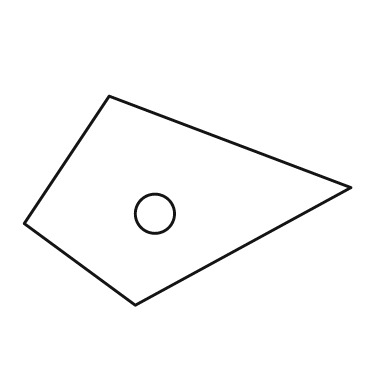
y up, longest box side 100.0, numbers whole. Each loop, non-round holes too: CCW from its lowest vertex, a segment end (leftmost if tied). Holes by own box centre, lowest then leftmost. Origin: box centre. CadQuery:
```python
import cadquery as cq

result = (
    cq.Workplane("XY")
    .moveTo(-16.0, -32.0)
    .lineTo(50.0, 4.0)
    .lineTo(-24.0, 32.0)
    .lineTo(-50.0, -7.0)
    .close()
    .moveTo(-10.0, -4.0)
    .circle(6.0)
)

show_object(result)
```